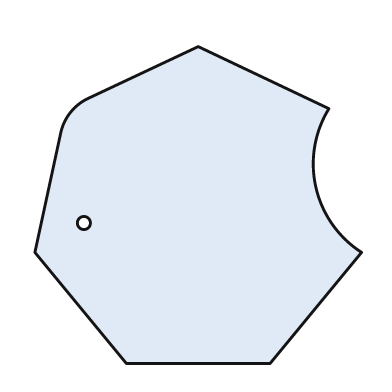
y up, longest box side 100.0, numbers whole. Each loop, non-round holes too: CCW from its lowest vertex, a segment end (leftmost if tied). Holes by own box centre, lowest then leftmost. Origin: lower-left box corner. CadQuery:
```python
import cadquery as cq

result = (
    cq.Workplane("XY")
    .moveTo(28.0, 0.0)
    .lineTo(72.0, 0.0)
    .lineTo(100.0, 34.0)
    .threePointArc((86.0, 54.0), (90.0, 78.0))
    .lineTo(50.0, 97.0)
    .lineTo(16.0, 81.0)
    .threePointArc((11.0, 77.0), (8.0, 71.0))
    .lineTo(0.0, 34.0)
    .close()
    .moveTo(15.0, 43.0)
    .circle(2.0)
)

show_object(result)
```